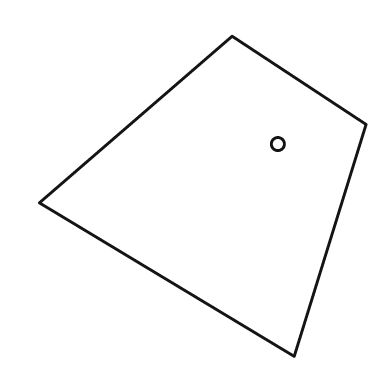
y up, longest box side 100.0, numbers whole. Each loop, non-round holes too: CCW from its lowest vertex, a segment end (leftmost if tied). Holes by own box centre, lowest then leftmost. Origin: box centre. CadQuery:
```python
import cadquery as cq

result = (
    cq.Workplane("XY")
    .moveTo(28.0, -49.0)
    .lineTo(50.0, 22.0)
    .lineTo(9.0, 49.0)
    .lineTo(-50.0, -2.0)
    .close()
    .moveTo(23.0, 16.0)
    .circle(2.0)
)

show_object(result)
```